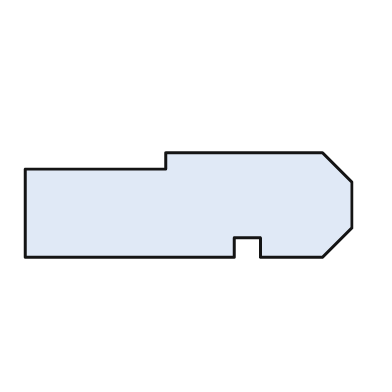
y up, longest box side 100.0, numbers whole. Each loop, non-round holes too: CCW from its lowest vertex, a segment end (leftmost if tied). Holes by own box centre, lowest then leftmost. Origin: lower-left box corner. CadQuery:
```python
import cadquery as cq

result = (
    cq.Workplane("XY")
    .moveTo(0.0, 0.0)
    .lineTo(64.0, 0.0)
    .lineTo(64.0, 6.0)
    .lineTo(72.0, 6.0)
    .lineTo(72.0, 0.0)
    .lineTo(91.0, 0.0)
    .lineTo(100.0, 9.0)
    .lineTo(100.0, 23.0)
    .lineTo(91.0, 32.0)
    .lineTo(43.0, 32.0)
    .lineTo(43.0, 27.0)
    .lineTo(0.0, 27.0)
    .close()
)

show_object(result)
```